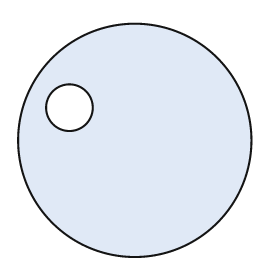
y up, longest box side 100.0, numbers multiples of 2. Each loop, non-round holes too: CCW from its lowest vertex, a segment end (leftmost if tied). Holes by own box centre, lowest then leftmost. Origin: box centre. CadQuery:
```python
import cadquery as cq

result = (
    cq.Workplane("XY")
    .moveTo(0.0, 0.0)
    .circle(50.0)
    .moveTo(-28.0, 14.0)
    .circle(10.0)
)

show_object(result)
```